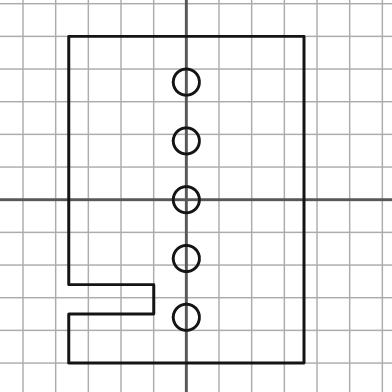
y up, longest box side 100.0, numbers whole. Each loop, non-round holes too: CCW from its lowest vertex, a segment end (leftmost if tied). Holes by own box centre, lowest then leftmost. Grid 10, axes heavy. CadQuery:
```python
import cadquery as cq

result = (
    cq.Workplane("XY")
    .moveTo(-36.0, -50.0)
    .lineTo(36.0, -50.0)
    .lineTo(36.0, 50.0)
    .lineTo(-36.0, 50.0)
    .lineTo(-36.0, -26.0)
    .lineTo(-10.0, -26.0)
    .lineTo(-10.0, -35.0)
    .lineTo(-36.0, -35.0)
    .close()
    .moveTo(0.0, -36.0)
    .circle(4.0)
    .moveTo(0.0, -18.0)
    .circle(4.0)
    .moveTo(0.0, 0.0)
    .circle(4.0)
    .moveTo(0.0, 18.0)
    .circle(4.0)
    .moveTo(0.0, 36.0)
    .circle(4.0)
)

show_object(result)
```